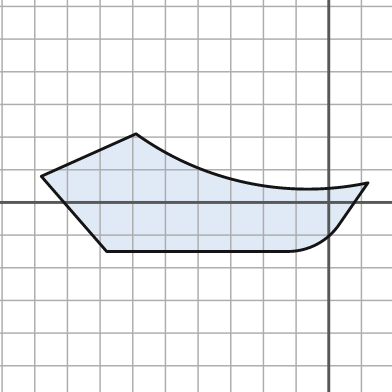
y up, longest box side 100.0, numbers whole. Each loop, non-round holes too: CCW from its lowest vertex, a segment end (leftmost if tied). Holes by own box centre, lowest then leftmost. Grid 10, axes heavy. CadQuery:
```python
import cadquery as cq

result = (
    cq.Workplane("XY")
    .moveTo(-68.0, -15.0)
    .lineTo(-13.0, -15.0)
    .threePointArc((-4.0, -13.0), (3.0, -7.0))
    .lineTo(12.0, 6.0)
    .threePointArc((-25.0, 6.0), (-59.0, 21.0))
    .lineTo(-88.0, 8.0)
    .close()
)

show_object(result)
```